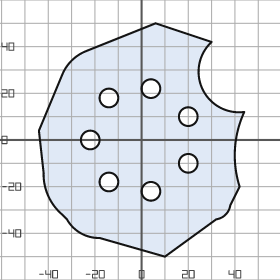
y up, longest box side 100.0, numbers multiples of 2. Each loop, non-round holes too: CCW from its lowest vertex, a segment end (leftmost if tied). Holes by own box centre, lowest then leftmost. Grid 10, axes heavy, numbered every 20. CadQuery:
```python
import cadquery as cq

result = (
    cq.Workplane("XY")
    .moveTo(10.0, -50.0)
    .lineTo(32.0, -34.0)
    .threePointArc((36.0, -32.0), (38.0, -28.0))
    .lineTo(42.0, -20.0)
    .threePointArc((40.0, -4.0), (44.0, 12.0))
    .threePointArc((26.0, 22.0), (30.0, 42.0))
    .lineTo(6.0, 50.0)
    .lineTo(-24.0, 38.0)
    .threePointArc((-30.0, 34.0), (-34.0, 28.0))
    .lineTo(-44.0, 4.0)
    .lineTo(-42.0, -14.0)
    .threePointArc((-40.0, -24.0), (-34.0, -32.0))
    .lineTo(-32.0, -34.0)
    .threePointArc((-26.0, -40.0), (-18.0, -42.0))
    .close()
    .moveTo(4.0, -22.0)
    .circle(4.0)
    .moveTo(-14.0, -18.0)
    .circle(4.0)
    .moveTo(20.0, -10.0)
    .circle(4.0)
    .moveTo(-22.0, 0.0)
    .circle(4.0)
    .moveTo(20.0, 10.0)
    .circle(4.0)
    .moveTo(-14.0, 18.0)
    .circle(4.0)
    .moveTo(4.0, 22.0)
    .circle(4.0)
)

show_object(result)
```